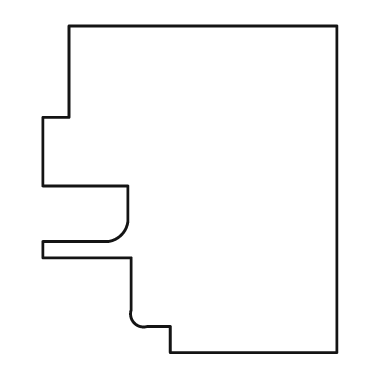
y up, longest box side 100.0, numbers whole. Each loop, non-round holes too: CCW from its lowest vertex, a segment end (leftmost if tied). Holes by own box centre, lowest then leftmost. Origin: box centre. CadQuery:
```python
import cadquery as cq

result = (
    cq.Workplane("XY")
    .moveTo(-6.0, -50.0)
    .lineTo(45.0, -50.0)
    .lineTo(45.0, 50.0)
    .lineTo(-37.0, 50.0)
    .lineTo(-37.0, 22.0)
    .lineTo(-45.0, 22.0)
    .lineTo(-45.0, 1.0)
    .lineTo(-19.0, 1.0)
    .lineTo(-19.0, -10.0)
    .threePointArc((-21.0, -14.0), (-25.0, -16.0))
    .lineTo(-45.0, -16.0)
    .lineTo(-45.0, -21.0)
    .lineTo(-18.0, -21.0)
    .lineTo(-18.0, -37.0)
    .threePointArc((-17.0, -41.0), (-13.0, -42.0))
    .lineTo(-6.0, -42.0)
    .close()
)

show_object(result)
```